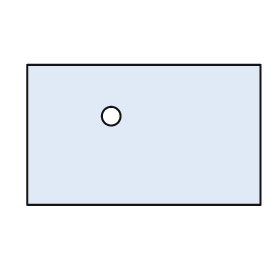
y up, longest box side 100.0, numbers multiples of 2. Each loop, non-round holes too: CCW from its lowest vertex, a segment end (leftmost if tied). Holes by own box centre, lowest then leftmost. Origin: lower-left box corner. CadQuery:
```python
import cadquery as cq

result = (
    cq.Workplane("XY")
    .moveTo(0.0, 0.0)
    .lineTo(100.0, 0.0)
    .lineTo(100.0, 60.0)
    .lineTo(0.0, 60.0)
    .close()
    .moveTo(36.0, 38.0)
    .circle(4.0)
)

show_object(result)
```